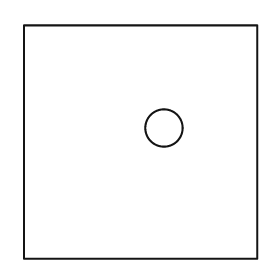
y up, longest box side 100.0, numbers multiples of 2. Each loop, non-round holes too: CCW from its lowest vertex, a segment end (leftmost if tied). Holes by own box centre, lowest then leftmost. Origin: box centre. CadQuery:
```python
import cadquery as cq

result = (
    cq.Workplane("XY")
    .moveTo(-50.0, -50.0)
    .lineTo(50.0, -50.0)
    .lineTo(50.0, 50.0)
    .lineTo(-50.0, 50.0)
    .close()
    .moveTo(10.0, 6.0)
    .circle(8.0)
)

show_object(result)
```